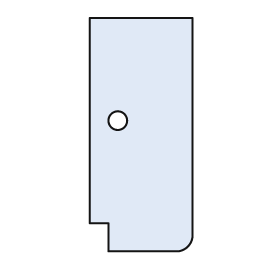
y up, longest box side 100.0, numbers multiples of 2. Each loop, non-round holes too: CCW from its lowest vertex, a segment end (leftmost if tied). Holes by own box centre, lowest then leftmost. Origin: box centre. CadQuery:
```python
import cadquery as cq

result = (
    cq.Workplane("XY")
    .moveTo(-14.0, -50.0)
    .lineTo(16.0, -50.0)
    .threePointArc((20.0, -48.0), (22.0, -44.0))
    .lineTo(22.0, 50.0)
    .lineTo(-22.0, 50.0)
    .lineTo(-22.0, -38.0)
    .lineTo(-14.0, -38.0)
    .close()
    .moveTo(-10.0, 6.0)
    .circle(4.0)
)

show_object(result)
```